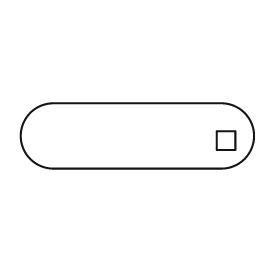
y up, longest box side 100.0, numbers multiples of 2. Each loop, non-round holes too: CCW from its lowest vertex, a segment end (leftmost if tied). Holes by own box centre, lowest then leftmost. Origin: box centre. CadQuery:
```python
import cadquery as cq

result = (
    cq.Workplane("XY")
    .moveTo(-36.0, -14.0)
    .lineTo(36.0, -14.0)
    .threePointArc((50.0, 0.0), (36.0, 14.0))
    .lineTo(-36.0, 14.0)
    .threePointArc((-50.0, 0.0), (-36.0, -14.0))
    .close()
    .moveTo(34.0, -6.0)
    .lineTo(42.0, -6.0)
    .lineTo(42.0, 2.0)
    .lineTo(34.0, 2.0)
    .close()
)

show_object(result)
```